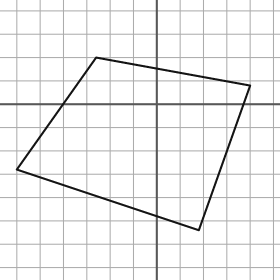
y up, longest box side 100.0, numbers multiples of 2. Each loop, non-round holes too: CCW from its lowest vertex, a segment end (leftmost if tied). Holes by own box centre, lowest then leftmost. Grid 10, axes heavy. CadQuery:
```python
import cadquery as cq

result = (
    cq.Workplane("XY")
    .moveTo(18.0, -54.0)
    .lineTo(40.0, 8.0)
    .lineTo(-26.0, 20.0)
    .lineTo(-60.0, -28.0)
    .close()
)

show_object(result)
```